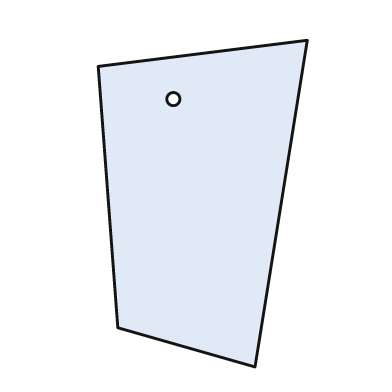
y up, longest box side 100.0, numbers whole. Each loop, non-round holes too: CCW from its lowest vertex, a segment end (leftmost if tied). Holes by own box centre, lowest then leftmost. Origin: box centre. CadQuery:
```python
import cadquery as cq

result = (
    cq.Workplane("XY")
    .moveTo(16.0, -50.0)
    .lineTo(32.0, 50.0)
    .lineTo(-32.0, 42.0)
    .lineTo(-26.0, -38.0)
    .close()
    .moveTo(-9.0, 32.0)
    .circle(2.0)
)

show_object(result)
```